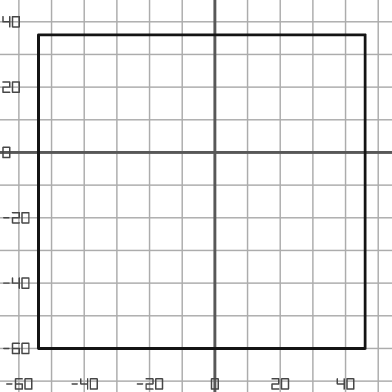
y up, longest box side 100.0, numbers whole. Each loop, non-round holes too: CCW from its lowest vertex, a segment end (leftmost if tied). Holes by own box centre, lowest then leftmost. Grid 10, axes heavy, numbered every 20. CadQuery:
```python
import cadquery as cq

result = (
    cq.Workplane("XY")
    .moveTo(-54.0, -60.0)
    .lineTo(46.0, -60.0)
    .lineTo(46.0, 36.0)
    .lineTo(-54.0, 36.0)
    .close()
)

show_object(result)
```